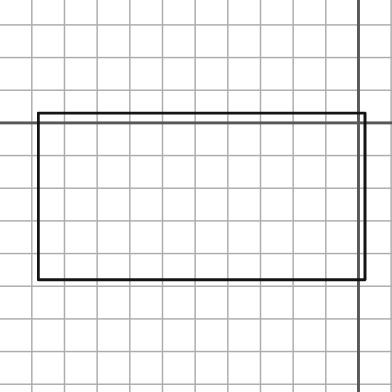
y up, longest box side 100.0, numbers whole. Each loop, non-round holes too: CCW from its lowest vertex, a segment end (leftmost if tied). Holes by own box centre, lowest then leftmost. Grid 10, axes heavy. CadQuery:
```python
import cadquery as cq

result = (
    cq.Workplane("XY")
    .moveTo(-98.0, -48.0)
    .lineTo(2.0, -48.0)
    .lineTo(2.0, 3.0)
    .lineTo(-98.0, 3.0)
    .close()
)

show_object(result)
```